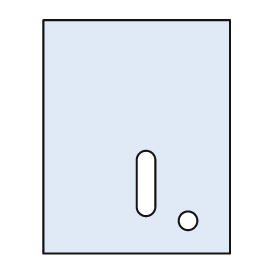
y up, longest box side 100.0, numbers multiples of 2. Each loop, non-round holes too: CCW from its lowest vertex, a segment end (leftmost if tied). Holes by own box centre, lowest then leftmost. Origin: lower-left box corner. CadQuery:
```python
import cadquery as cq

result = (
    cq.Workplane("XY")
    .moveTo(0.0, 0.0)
    .lineTo(80.0, 0.0)
    .lineTo(80.0, 100.0)
    .lineTo(0.0, 100.0)
    .close()
    .moveTo(62.0, 14.0)
    .circle(4.0)
    .moveTo(40.0, 20.0)
    .threePointArc((44.0, 16.0), (48.0, 20.0))
    .lineTo(48.0, 40.0)
    .threePointArc((44.0, 44.0), (40.0, 40.0))
    .close()
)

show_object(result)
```